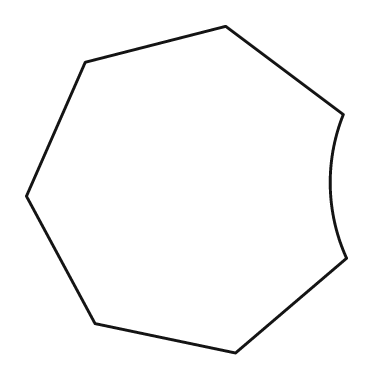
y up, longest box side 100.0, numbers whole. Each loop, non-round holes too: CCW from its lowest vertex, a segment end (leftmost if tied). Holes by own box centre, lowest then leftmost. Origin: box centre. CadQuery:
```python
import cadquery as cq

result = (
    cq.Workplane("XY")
    .moveTo(15.0, -50.0)
    .lineTo(49.0, -21.0)
    .threePointArc((44.0, 1.0), (48.0, 23.0))
    .lineTo(12.0, 50.0)
    .lineTo(-31.0, 39.0)
    .lineTo(-49.0, -2.0)
    .lineTo(-28.0, -41.0)
    .close()
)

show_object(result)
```